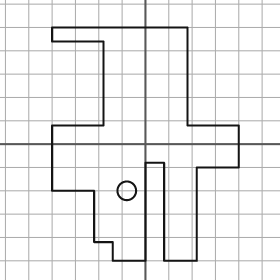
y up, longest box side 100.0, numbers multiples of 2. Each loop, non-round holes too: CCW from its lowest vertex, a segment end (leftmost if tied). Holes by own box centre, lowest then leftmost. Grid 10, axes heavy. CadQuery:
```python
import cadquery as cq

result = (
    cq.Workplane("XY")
    .moveTo(-14.0, -50.0)
    .lineTo(0.0, -50.0)
    .lineTo(0.0, -8.0)
    .lineTo(8.0, -8.0)
    .lineTo(8.0, -50.0)
    .lineTo(22.0, -50.0)
    .lineTo(22.0, -10.0)
    .lineTo(40.0, -10.0)
    .lineTo(40.0, 8.0)
    .lineTo(18.0, 8.0)
    .lineTo(18.0, 50.0)
    .lineTo(-40.0, 50.0)
    .lineTo(-40.0, 44.0)
    .lineTo(-18.0, 44.0)
    .lineTo(-18.0, 8.0)
    .lineTo(-40.0, 8.0)
    .lineTo(-40.0, -20.0)
    .lineTo(-22.0, -20.0)
    .lineTo(-22.0, -42.0)
    .lineTo(-14.0, -42.0)
    .close()
    .moveTo(-8.0, -20.0)
    .circle(4.0)
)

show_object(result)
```